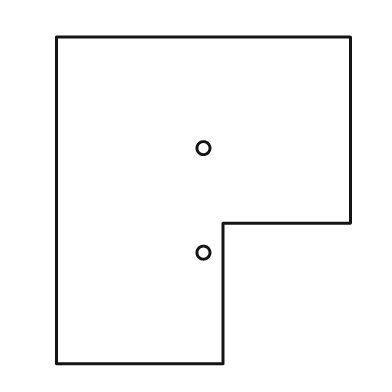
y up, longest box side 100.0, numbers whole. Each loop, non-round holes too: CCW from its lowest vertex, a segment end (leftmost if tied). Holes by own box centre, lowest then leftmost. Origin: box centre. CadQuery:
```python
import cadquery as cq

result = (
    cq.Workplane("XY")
    .moveTo(-45.0, -50.0)
    .lineTo(6.0, -50.0)
    .lineTo(6.0, -7.0)
    .lineTo(45.0, -7.0)
    .lineTo(45.0, 50.0)
    .lineTo(-45.0, 50.0)
    .close()
    .moveTo(0.0, -16.0)
    .circle(2.0)
    .moveTo(0.0, 16.0)
    .circle(2.0)
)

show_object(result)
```